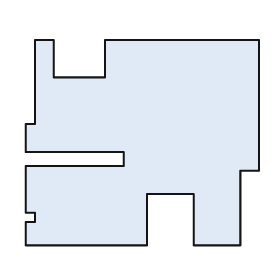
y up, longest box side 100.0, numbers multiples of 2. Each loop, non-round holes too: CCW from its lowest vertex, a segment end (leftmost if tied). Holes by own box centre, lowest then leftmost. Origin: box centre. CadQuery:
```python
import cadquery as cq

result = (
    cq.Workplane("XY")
    .moveTo(-50.0, -44.0)
    .lineTo(2.0, -44.0)
    .lineTo(2.0, -22.0)
    .lineTo(22.0, -22.0)
    .lineTo(22.0, -44.0)
    .lineTo(42.0, -44.0)
    .lineTo(42.0, -12.0)
    .lineTo(50.0, -12.0)
    .lineTo(50.0, 44.0)
    .lineTo(-16.0, 44.0)
    .lineTo(-16.0, 28.0)
    .lineTo(-38.0, 28.0)
    .lineTo(-38.0, 44.0)
    .lineTo(-46.0, 44.0)
    .lineTo(-46.0, 8.0)
    .lineTo(-50.0, 8.0)
    .lineTo(-50.0, -4.0)
    .lineTo(-8.0, -4.0)
    .lineTo(-8.0, -10.0)
    .lineTo(-50.0, -10.0)
    .lineTo(-50.0, -30.0)
    .lineTo(-46.0, -30.0)
    .lineTo(-46.0, -34.0)
    .lineTo(-50.0, -34.0)
    .close()
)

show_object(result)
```